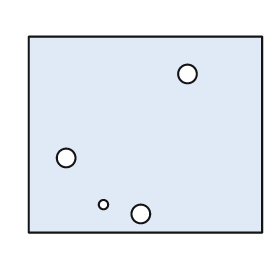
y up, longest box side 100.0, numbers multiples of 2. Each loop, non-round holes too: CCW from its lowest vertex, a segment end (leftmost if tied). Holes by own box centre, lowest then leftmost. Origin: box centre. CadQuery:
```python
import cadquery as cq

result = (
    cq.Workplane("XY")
    .moveTo(-50.0, -42.0)
    .lineTo(50.0, -42.0)
    .lineTo(50.0, 42.0)
    .lineTo(-50.0, 42.0)
    .close()
    .moveTo(-2.0, -34.0)
    .circle(4.0)
    .moveTo(-18.0, -30.0)
    .circle(2.0)
    .moveTo(-34.0, -10.0)
    .circle(4.0)
    .moveTo(18.0, 26.0)
    .circle(4.0)
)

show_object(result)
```